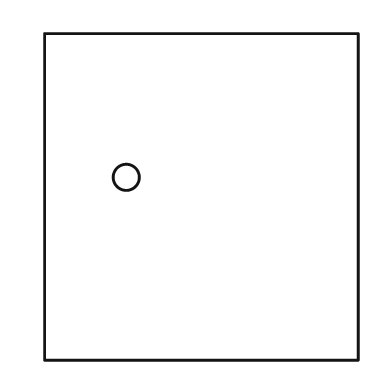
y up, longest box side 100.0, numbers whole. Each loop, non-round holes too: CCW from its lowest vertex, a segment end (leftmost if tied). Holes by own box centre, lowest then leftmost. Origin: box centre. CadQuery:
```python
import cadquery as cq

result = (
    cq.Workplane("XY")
    .moveTo(-48.0, -50.0)
    .lineTo(48.0, -50.0)
    .lineTo(48.0, 50.0)
    .lineTo(-48.0, 50.0)
    .close()
    .moveTo(-23.0, 6.0)
    .circle(4.0)
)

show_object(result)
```